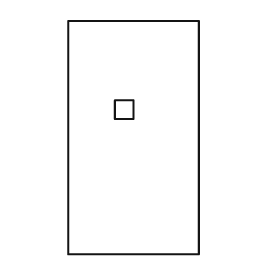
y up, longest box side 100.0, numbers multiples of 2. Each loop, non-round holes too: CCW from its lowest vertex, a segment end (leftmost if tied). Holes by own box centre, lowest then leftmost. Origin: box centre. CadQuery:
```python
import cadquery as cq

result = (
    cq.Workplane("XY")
    .moveTo(-28.0, -50.0)
    .lineTo(28.0, -50.0)
    .lineTo(28.0, 50.0)
    .lineTo(-28.0, 50.0)
    .close()
    .moveTo(-8.0, 8.0)
    .lineTo(0.0, 8.0)
    .lineTo(0.0, 16.0)
    .lineTo(-8.0, 16.0)
    .close()
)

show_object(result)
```